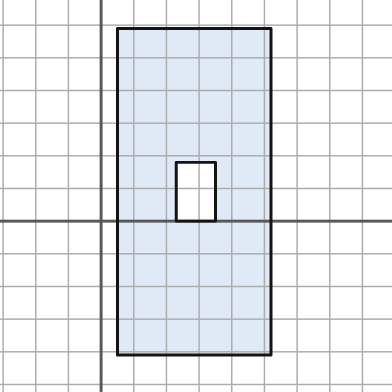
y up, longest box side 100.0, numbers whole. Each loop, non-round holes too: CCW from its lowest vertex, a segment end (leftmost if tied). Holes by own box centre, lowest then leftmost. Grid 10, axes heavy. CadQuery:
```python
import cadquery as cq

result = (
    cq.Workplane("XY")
    .moveTo(5.0, -41.0)
    .lineTo(52.0, -41.0)
    .lineTo(52.0, 59.0)
    .lineTo(5.0, 59.0)
    .close()
    .moveTo(23.0, 0.0)
    .lineTo(35.0, 0.0)
    .lineTo(35.0, 18.0)
    .lineTo(23.0, 18.0)
    .close()
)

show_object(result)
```